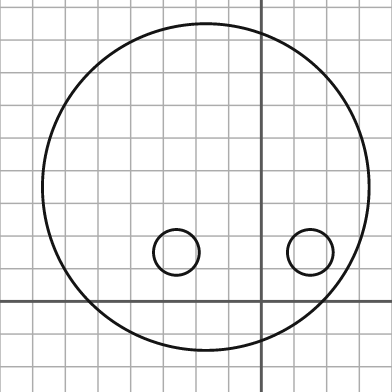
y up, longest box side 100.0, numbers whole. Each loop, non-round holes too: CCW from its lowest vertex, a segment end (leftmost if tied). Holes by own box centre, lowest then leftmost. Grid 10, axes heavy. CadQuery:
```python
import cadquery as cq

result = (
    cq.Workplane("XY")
    .moveTo(-17.0, 35.0)
    .circle(50.0)
    .moveTo(-26.0, 15.0)
    .circle(7.0)
    .moveTo(15.0, 15.0)
    .circle(7.0)
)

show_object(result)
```